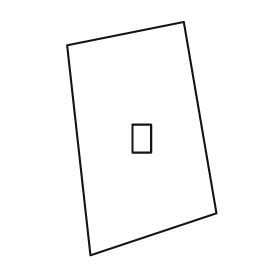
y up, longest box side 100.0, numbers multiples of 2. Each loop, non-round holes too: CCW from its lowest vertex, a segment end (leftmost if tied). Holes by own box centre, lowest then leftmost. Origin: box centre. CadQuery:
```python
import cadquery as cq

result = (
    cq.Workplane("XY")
    .moveTo(-22.0, -50.0)
    .lineTo(32.0, -32.0)
    .lineTo(18.0, 50.0)
    .lineTo(-32.0, 40.0)
    .close()
    .moveTo(-4.0, -6.0)
    .lineTo(4.0, -6.0)
    .lineTo(4.0, 6.0)
    .lineTo(-4.0, 6.0)
    .close()
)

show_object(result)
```